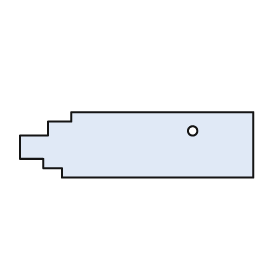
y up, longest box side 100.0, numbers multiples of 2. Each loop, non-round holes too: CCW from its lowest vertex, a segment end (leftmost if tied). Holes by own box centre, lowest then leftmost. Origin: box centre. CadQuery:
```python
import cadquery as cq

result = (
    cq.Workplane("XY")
    .moveTo(-32.0, -14.0)
    .lineTo(50.0, -14.0)
    .lineTo(50.0, 14.0)
    .lineTo(-28.0, 14.0)
    .lineTo(-28.0, 10.0)
    .lineTo(-38.0, 10.0)
    .lineTo(-38.0, 4.0)
    .lineTo(-50.0, 4.0)
    .lineTo(-50.0, -6.0)
    .lineTo(-40.0, -6.0)
    .lineTo(-40.0, -10.0)
    .lineTo(-32.0, -10.0)
    .close()
    .moveTo(24.0, 6.0)
    .circle(2.0)
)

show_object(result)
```